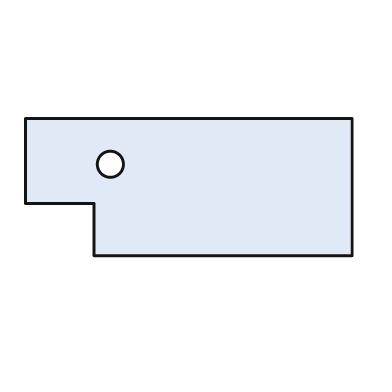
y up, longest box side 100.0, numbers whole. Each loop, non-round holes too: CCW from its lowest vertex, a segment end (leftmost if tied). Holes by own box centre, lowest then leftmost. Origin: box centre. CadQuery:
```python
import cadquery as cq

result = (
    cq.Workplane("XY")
    .moveTo(-29.0, -21.0)
    .lineTo(50.0, -21.0)
    .lineTo(50.0, 21.0)
    .lineTo(-50.0, 21.0)
    .lineTo(-50.0, -5.0)
    .lineTo(-29.0, -5.0)
    .close()
    .moveTo(-24.0, 7.0)
    .circle(4.0)
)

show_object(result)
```